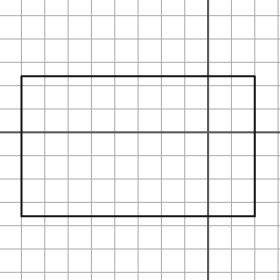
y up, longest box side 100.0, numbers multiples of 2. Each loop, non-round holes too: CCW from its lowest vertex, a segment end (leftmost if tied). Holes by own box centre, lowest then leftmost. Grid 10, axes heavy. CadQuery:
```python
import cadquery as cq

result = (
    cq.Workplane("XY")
    .moveTo(-80.0, -36.0)
    .lineTo(20.0, -36.0)
    .lineTo(20.0, 24.0)
    .lineTo(-80.0, 24.0)
    .close()
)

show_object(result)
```